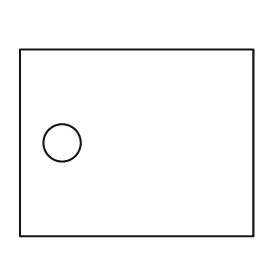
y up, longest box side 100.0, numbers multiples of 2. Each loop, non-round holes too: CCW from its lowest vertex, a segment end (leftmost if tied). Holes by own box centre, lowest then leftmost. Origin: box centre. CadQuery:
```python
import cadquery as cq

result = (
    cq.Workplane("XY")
    .moveTo(-50.0, -40.0)
    .lineTo(50.0, -40.0)
    .lineTo(50.0, 40.0)
    .lineTo(-50.0, 40.0)
    .close()
    .moveTo(-32.0, 0.0)
    .circle(8.0)
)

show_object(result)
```